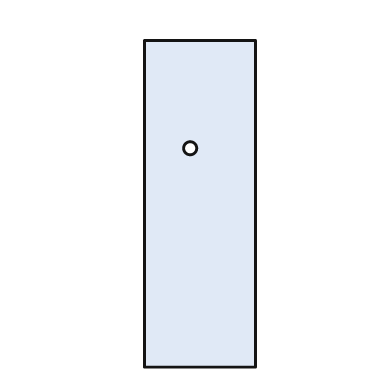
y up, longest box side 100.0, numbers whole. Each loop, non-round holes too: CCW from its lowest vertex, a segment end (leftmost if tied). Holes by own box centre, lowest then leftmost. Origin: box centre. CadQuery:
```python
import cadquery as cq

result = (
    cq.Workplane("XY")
    .moveTo(-17.0, -50.0)
    .lineTo(17.0, -50.0)
    .lineTo(17.0, 50.0)
    .lineTo(-17.0, 50.0)
    .close()
    .moveTo(-3.0, 17.0)
    .circle(2.0)
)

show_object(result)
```